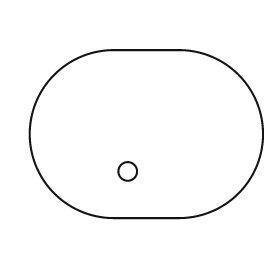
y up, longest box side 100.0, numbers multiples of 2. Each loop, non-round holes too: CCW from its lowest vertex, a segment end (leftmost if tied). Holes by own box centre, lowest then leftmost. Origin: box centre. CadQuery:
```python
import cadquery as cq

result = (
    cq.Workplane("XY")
    .moveTo(-14.0, -36.0)
    .lineTo(14.0, -36.0)
    .threePointArc((50.0, 0.0), (14.0, 36.0))
    .lineTo(-14.0, 36.0)
    .threePointArc((-50.0, 0.0), (-14.0, -36.0))
    .close()
    .moveTo(-8.0, -16.0)
    .circle(4.0)
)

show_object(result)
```